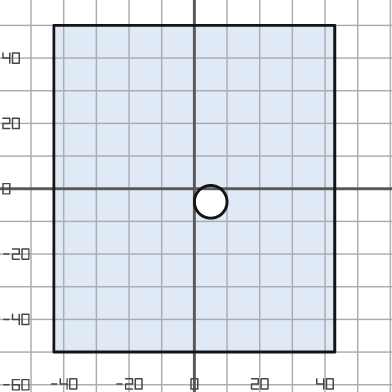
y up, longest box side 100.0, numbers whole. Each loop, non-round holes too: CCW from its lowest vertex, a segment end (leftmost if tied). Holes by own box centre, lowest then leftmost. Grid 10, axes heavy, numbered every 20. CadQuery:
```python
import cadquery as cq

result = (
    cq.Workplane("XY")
    .moveTo(-43.0, -50.0)
    .lineTo(43.0, -50.0)
    .lineTo(43.0, 50.0)
    .lineTo(-43.0, 50.0)
    .close()
    .moveTo(5.0, -4.0)
    .circle(5.0)
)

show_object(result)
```